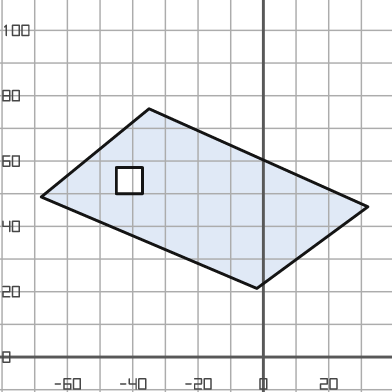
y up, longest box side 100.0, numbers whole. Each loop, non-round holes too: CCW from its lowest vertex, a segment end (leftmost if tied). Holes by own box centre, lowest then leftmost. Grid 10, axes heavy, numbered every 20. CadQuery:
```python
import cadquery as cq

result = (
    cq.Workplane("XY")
    .moveTo(-2.0, 21.0)
    .lineTo(32.0, 46.0)
    .lineTo(-35.0, 76.0)
    .lineTo(-68.0, 49.0)
    .close()
    .moveTo(-45.0, 50.0)
    .lineTo(-37.0, 50.0)
    .lineTo(-37.0, 58.0)
    .lineTo(-45.0, 58.0)
    .close()
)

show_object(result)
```